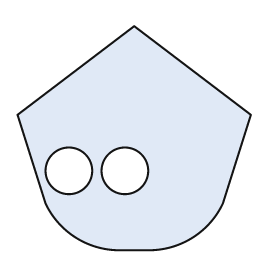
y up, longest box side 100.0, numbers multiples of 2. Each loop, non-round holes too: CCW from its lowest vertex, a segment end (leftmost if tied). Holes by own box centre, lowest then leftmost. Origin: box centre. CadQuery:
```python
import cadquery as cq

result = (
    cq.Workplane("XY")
    .moveTo(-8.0, -48.0)
    .lineTo(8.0, -48.0)
    .threePointArc((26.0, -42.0), (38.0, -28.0))
    .lineTo(50.0, 10.0)
    .lineTo(0.0, 48.0)
    .lineTo(-50.0, 10.0)
    .lineTo(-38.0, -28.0)
    .threePointArc((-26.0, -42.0), (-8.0, -48.0))
    .close()
    .moveTo(-28.0, -14.0)
    .circle(10.0)
    .moveTo(-4.0, -14.0)
    .circle(10.0)
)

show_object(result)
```